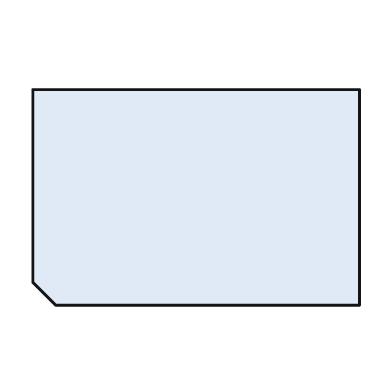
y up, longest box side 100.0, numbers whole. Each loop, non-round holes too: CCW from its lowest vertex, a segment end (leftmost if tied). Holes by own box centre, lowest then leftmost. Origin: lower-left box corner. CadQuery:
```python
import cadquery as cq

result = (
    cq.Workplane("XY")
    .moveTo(7.0, 0.0)
    .lineTo(100.0, 0.0)
    .lineTo(100.0, 66.0)
    .lineTo(0.0, 66.0)
    .lineTo(0.0, 7.0)
    .close()
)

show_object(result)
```